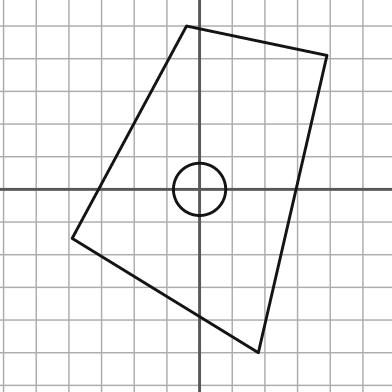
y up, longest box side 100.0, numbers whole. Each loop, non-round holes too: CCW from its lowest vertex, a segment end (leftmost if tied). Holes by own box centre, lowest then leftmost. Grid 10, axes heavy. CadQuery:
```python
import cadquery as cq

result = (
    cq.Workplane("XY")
    .moveTo(18.0, -50.0)
    .lineTo(39.0, 41.0)
    .lineTo(-4.0, 50.0)
    .lineTo(-39.0, -15.0)
    .close()
    .moveTo(0.0, 0.0)
    .circle(8.0)
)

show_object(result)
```